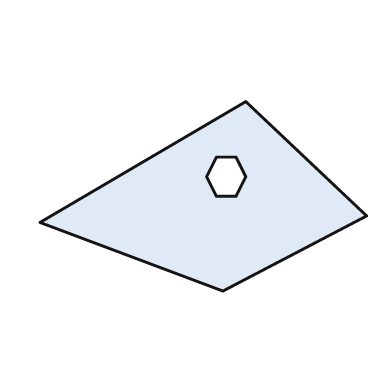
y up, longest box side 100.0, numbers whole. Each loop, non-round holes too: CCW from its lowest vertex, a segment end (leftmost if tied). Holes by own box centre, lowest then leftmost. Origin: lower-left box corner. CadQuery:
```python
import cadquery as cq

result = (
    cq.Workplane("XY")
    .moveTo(56.0, 0.0)
    .lineTo(100.0, 23.0)
    .lineTo(63.0, 58.0)
    .lineTo(0.0, 21.0)
    .close()
    .moveTo(54.0, 29.0)
    .lineTo(60.0, 29.0)
    .lineTo(63.0, 35.0)
    .lineTo(60.0, 41.0)
    .lineTo(54.0, 41.0)
    .lineTo(51.0, 35.0)
    .close()
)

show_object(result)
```